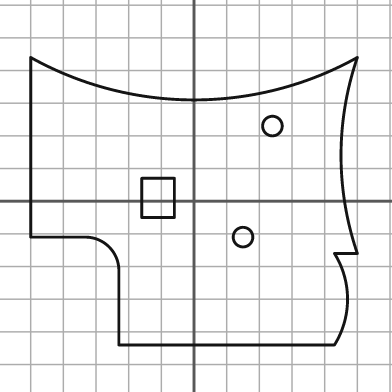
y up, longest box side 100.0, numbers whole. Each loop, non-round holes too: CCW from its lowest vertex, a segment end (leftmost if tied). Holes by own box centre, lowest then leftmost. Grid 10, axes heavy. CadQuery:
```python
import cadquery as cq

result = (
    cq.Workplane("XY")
    .moveTo(-23.0, -44.0)
    .lineTo(43.0, -44.0)
    .threePointArc((47.0, -30.0), (43.0, -16.0))
    .lineTo(50.0, -16.0)
    .threePointArc((45.0, 14.0), (50.0, 44.0))
    .threePointArc((0.0, 31.0), (-50.0, 44.0))
    .lineTo(-50.0, -11.0)
    .lineTo(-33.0, -11.0)
    .threePointArc((-26.0, -14.0), (-23.0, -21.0))
    .close()
    .moveTo(15.0, -11.0)
    .circle(3.0)
    .moveTo(-16.0, -5.0)
    .lineTo(-6.0, -5.0)
    .lineTo(-6.0, 7.0)
    .lineTo(-16.0, 7.0)
    .close()
    .moveTo(24.0, 23.0)
    .circle(3.0)
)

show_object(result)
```